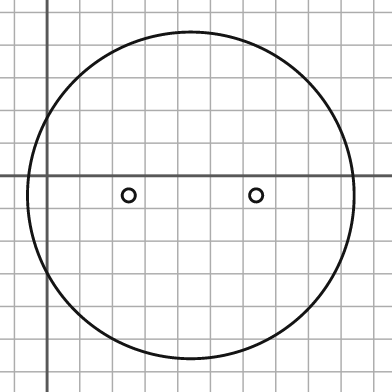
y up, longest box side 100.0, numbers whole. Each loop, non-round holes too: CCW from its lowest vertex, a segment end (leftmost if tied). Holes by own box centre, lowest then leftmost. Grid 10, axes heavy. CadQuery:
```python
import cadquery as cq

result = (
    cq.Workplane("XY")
    .moveTo(44.0, -6.0)
    .circle(50.0)
    .moveTo(25.0, -6.0)
    .circle(2.0)
    .moveTo(64.0, -6.0)
    .circle(2.0)
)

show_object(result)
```